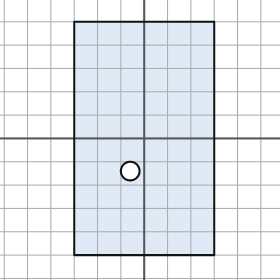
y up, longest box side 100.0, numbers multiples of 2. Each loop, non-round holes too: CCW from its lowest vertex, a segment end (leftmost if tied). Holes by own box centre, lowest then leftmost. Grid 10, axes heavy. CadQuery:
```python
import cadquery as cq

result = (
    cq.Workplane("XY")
    .moveTo(-30.0, -50.0)
    .lineTo(30.0, -50.0)
    .lineTo(30.0, 50.0)
    .lineTo(-30.0, 50.0)
    .close()
    .moveTo(-6.0, -14.0)
    .circle(4.0)
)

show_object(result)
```